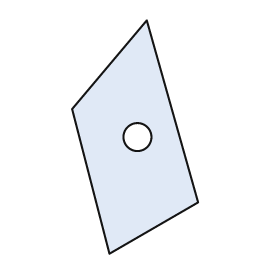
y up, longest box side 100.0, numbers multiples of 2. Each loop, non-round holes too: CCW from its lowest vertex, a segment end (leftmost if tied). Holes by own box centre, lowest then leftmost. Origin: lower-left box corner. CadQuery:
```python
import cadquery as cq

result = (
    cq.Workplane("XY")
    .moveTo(16.0, 0.0)
    .lineTo(54.0, 22.0)
    .lineTo(32.0, 100.0)
    .lineTo(0.0, 62.0)
    .close()
    .moveTo(28.0, 50.0)
    .circle(6.0)
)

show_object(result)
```